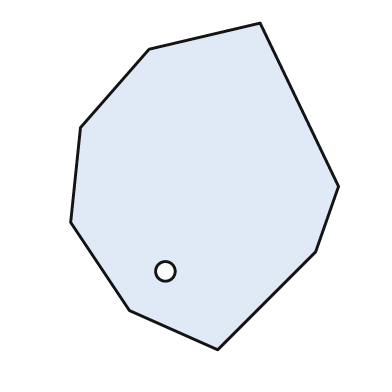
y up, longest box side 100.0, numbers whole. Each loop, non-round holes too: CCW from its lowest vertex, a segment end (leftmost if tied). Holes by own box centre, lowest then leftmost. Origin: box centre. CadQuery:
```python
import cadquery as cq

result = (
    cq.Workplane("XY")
    .moveTo(4.0, -50.0)
    .lineTo(34.0, -20.0)
    .lineTo(41.0, 0.0)
    .lineTo(17.0, 50.0)
    .lineTo(-17.0, 42.0)
    .lineTo(-38.0, 18.0)
    .lineTo(-41.0, -11.0)
    .lineTo(-23.0, -38.0)
    .close()
    .moveTo(-12.0, -26.0)
    .circle(3.0)
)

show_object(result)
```